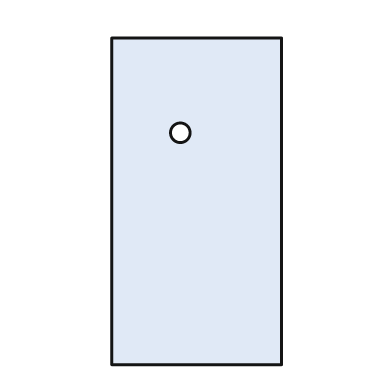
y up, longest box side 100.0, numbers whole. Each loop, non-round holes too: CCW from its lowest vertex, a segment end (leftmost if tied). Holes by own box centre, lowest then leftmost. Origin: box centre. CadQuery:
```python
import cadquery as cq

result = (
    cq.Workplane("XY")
    .moveTo(-26.0, -50.0)
    .lineTo(26.0, -50.0)
    .lineTo(26.0, 50.0)
    .lineTo(-26.0, 50.0)
    .close()
    .moveTo(-5.0, 21.0)
    .circle(3.0)
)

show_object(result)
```